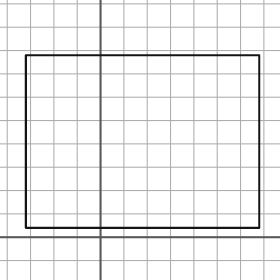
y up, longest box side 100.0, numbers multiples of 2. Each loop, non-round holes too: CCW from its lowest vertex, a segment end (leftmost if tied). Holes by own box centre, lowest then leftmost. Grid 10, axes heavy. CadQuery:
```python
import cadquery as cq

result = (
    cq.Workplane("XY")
    .moveTo(-32.0, 4.0)
    .lineTo(68.0, 4.0)
    .lineTo(68.0, 78.0)
    .lineTo(-32.0, 78.0)
    .close()
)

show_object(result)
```